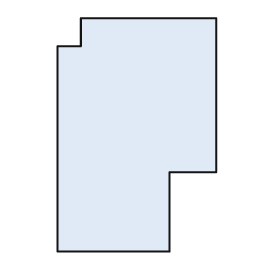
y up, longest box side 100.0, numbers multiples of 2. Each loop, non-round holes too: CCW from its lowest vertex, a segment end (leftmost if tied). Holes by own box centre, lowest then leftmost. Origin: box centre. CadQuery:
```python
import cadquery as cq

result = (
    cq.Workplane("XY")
    .moveTo(-34.0, -50.0)
    .lineTo(14.0, -50.0)
    .lineTo(14.0, -16.0)
    .lineTo(34.0, -16.0)
    .lineTo(34.0, 50.0)
    .lineTo(-24.0, 50.0)
    .lineTo(-24.0, 38.0)
    .lineTo(-34.0, 38.0)
    .close()
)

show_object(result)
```